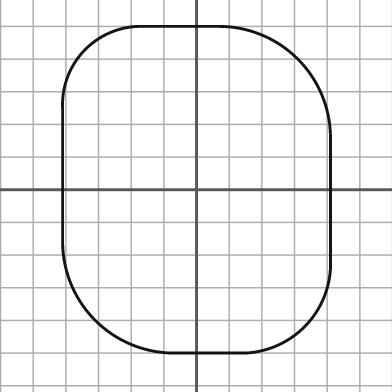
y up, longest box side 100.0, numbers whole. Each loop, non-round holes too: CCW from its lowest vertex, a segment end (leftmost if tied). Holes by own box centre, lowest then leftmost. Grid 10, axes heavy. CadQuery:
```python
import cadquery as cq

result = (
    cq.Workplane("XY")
    .moveTo(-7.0, -50.0)
    .lineTo(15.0, -50.0)
    .threePointArc((33.0, -42.0), (41.0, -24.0))
    .lineTo(41.0, 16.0)
    .threePointArc((31.0, 40.0), (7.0, 50.0))
    .lineTo(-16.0, 50.0)
    .threePointArc((-34.0, 43.0), (-41.0, 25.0))
    .lineTo(-41.0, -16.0)
    .threePointArc((-31.0, -40.0), (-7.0, -50.0))
    .close()
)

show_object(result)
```